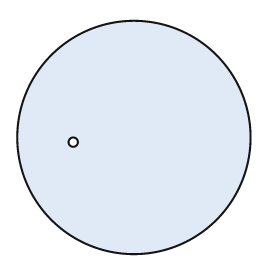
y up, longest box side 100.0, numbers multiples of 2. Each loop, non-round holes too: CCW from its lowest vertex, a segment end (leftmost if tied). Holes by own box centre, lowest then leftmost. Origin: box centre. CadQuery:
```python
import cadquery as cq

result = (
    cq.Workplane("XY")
    .moveTo(0.0, 0.0)
    .circle(50.0)
    .moveTo(-26.0, -2.0)
    .circle(2.0)
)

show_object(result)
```